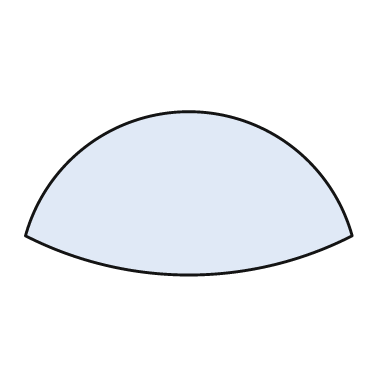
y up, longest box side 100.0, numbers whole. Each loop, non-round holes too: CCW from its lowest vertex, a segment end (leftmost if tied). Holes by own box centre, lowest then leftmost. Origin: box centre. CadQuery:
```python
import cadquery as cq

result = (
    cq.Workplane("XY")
    .moveTo(-50.0, -13.0)
    .threePointArc((0.0, -25.0), (50.0, -13.0))
    .threePointArc((0.0, 25.0), (-50.0, -13.0))
    .close()
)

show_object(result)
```